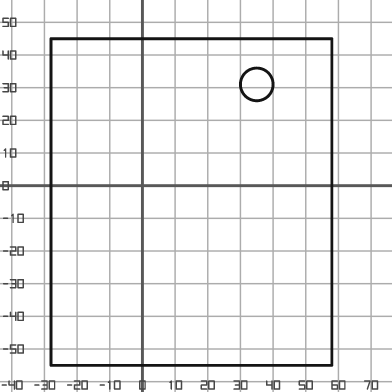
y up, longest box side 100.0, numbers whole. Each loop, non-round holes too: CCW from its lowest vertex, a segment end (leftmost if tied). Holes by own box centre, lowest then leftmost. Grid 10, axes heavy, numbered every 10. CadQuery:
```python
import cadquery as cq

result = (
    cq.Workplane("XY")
    .moveTo(-28.0, -55.0)
    .lineTo(58.0, -55.0)
    .lineTo(58.0, 45.0)
    .lineTo(-28.0, 45.0)
    .close()
    .moveTo(35.0, 31.0)
    .circle(5.0)
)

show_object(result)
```